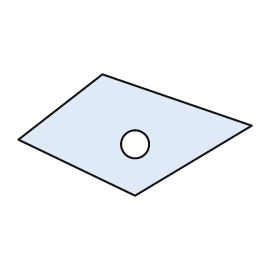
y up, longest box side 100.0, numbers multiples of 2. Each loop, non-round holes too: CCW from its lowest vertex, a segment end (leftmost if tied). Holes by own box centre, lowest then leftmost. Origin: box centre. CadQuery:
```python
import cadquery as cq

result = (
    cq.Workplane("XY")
    .moveTo(0.0, -26.0)
    .lineTo(50.0, 4.0)
    .lineTo(-14.0, 26.0)
    .lineTo(-50.0, -2.0)
    .close()
    .moveTo(0.0, -4.0)
    .circle(6.0)
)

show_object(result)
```